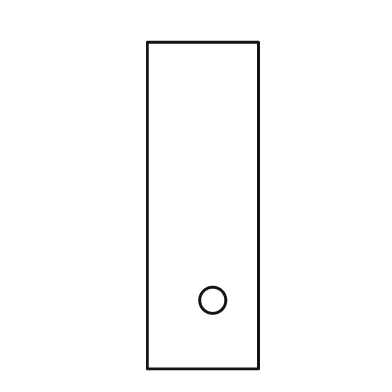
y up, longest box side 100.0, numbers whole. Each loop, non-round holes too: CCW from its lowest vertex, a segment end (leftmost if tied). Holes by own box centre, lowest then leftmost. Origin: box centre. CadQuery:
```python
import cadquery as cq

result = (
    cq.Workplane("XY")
    .moveTo(-17.0, -50.0)
    .lineTo(17.0, -50.0)
    .lineTo(17.0, 50.0)
    .lineTo(-17.0, 50.0)
    .close()
    .moveTo(3.0, -29.0)
    .circle(4.0)
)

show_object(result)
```